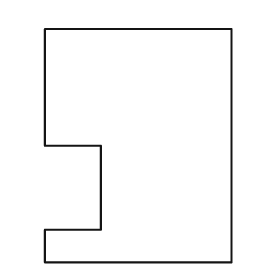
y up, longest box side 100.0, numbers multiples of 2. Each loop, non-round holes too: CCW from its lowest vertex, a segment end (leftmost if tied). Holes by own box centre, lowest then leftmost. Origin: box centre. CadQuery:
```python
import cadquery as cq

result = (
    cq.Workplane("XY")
    .moveTo(-40.0, -50.0)
    .lineTo(40.0, -50.0)
    .lineTo(40.0, 50.0)
    .lineTo(-40.0, 50.0)
    .lineTo(-40.0, 0.0)
    .lineTo(-16.0, 0.0)
    .lineTo(-16.0, -36.0)
    .lineTo(-40.0, -36.0)
    .close()
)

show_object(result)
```